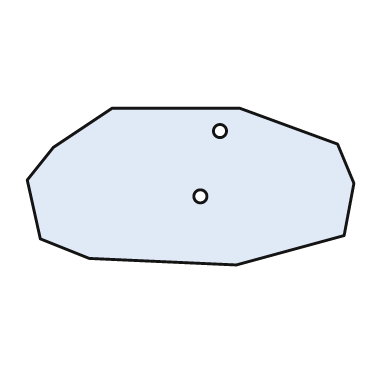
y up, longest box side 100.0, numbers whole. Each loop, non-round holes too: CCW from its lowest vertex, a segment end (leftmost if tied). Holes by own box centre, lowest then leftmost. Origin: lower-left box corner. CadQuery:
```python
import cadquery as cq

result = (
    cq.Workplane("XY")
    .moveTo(64.0, 0.0)
    .lineTo(97.0, 9.0)
    .lineTo(100.0, 25.0)
    .lineTo(95.0, 37.0)
    .lineTo(65.0, 48.0)
    .lineTo(26.0, 48.0)
    .lineTo(8.0, 36.0)
    .lineTo(0.0, 26.0)
    .lineTo(4.0, 8.0)
    .lineTo(19.0, 2.0)
    .close()
    .moveTo(53.0, 21.0)
    .circle(2.0)
    .moveTo(59.0, 41.0)
    .circle(2.0)
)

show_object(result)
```